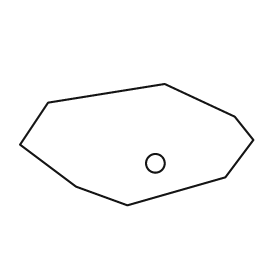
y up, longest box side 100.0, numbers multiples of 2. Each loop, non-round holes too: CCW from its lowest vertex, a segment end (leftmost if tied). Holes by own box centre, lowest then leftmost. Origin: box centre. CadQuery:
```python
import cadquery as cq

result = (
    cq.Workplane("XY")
    .moveTo(-4.0, -26.0)
    .lineTo(38.0, -14.0)
    .lineTo(50.0, 2.0)
    .lineTo(42.0, 12.0)
    .lineTo(12.0, 26.0)
    .lineTo(-38.0, 18.0)
    .lineTo(-50.0, 0.0)
    .lineTo(-26.0, -18.0)
    .close()
    .moveTo(8.0, -8.0)
    .circle(4.0)
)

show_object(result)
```